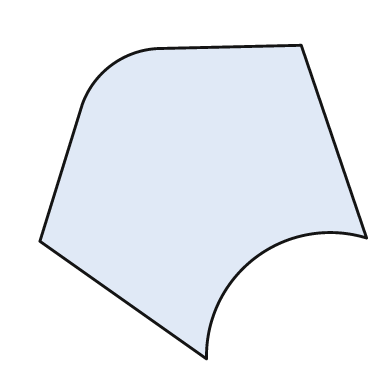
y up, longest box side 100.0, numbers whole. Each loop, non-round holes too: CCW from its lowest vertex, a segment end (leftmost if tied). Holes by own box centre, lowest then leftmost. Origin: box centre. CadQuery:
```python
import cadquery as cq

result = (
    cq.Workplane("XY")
    .moveTo(1.0, -48.0)
    .threePointArc((16.0, -17.0), (50.0, -11.0))
    .lineTo(30.0, 48.0)
    .lineTo(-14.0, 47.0)
    .threePointArc((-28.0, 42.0), (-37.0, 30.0))
    .lineTo(-50.0, -12.0)
    .close()
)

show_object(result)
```